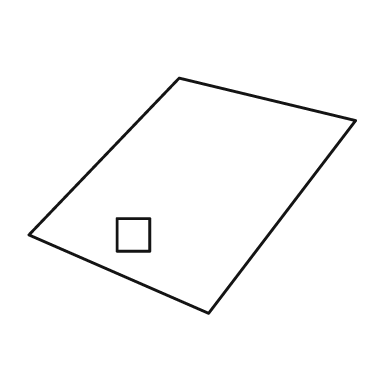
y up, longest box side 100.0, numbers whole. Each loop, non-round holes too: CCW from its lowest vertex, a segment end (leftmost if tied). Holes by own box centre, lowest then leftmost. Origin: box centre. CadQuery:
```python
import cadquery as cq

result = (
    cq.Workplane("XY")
    .moveTo(5.0, -36.0)
    .lineTo(50.0, 23.0)
    .lineTo(-4.0, 36.0)
    .lineTo(-50.0, -12.0)
    .close()
    .moveTo(-23.0, -17.0)
    .lineTo(-13.0, -17.0)
    .lineTo(-13.0, -7.0)
    .lineTo(-23.0, -7.0)
    .close()
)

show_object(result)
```